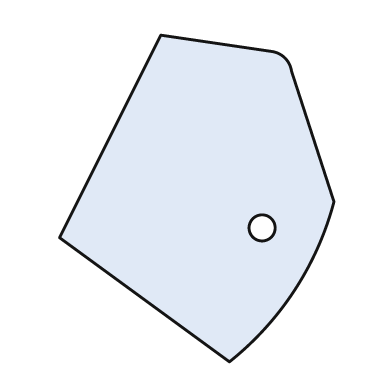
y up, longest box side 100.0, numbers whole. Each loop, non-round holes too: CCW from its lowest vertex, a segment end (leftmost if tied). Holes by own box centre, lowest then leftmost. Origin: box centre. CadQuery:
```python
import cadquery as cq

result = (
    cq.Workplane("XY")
    .moveTo(10.0, -50.0)
    .threePointArc((30.0, -28.0), (42.0, -1.0))
    .lineTo(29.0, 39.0)
    .threePointArc((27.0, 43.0), (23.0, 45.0))
    .lineTo(-11.0, 50.0)
    .lineTo(-42.0, -12.0)
    .close()
    .moveTo(20.0, -9.0)
    .circle(4.0)
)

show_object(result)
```